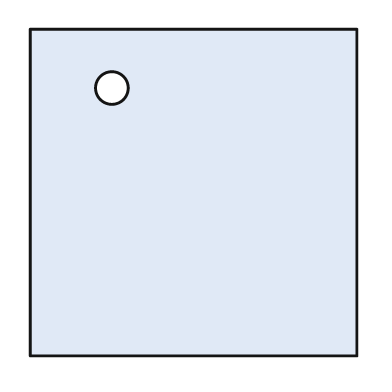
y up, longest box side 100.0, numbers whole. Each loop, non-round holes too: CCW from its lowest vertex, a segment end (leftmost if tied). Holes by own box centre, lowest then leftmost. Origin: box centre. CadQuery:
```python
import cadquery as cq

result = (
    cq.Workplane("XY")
    .moveTo(-50.0, -50.0)
    .lineTo(50.0, -50.0)
    .lineTo(50.0, 50.0)
    .lineTo(-50.0, 50.0)
    .close()
    .moveTo(-25.0, 32.0)
    .circle(5.0)
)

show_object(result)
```